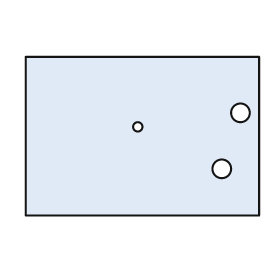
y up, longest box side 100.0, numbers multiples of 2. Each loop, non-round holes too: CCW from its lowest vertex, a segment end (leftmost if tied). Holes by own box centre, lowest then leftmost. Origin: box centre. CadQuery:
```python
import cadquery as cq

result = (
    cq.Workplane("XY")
    .moveTo(-50.0, -34.0)
    .lineTo(50.0, -34.0)
    .lineTo(50.0, 34.0)
    .lineTo(-50.0, 34.0)
    .close()
    .moveTo(34.0, -14.0)
    .circle(4.0)
    .moveTo(-2.0, 4.0)
    .circle(2.0)
    .moveTo(42.0, 10.0)
    .circle(4.0)
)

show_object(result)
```